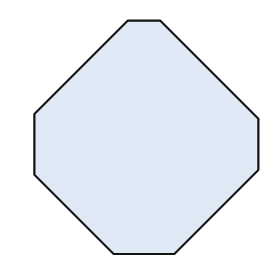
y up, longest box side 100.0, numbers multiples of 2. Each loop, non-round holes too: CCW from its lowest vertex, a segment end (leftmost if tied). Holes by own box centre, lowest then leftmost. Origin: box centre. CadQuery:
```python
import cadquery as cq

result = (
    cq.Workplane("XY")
    .moveTo(-14.0, -50.0)
    .lineTo(12.0, -50.0)
    .lineTo(48.0, -14.0)
    .lineTo(48.0, 8.0)
    .lineTo(6.0, 50.0)
    .lineTo(-8.0, 50.0)
    .lineTo(-48.0, 10.0)
    .lineTo(-48.0, -16.0)
    .close()
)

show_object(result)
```